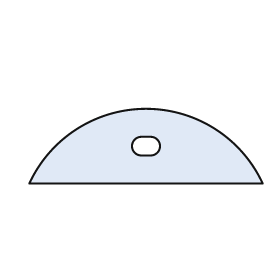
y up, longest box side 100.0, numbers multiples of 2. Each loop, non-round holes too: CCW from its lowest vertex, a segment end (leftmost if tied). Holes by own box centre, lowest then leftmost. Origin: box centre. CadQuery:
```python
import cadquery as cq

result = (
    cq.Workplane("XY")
    .moveTo(-50.0, -16.0)
    .lineTo(50.0, -16.0)
    .threePointArc((0.0, 16.0), (-50.0, -16.0))
    .close()
    .moveTo(-2.0, -4.0)
    .lineTo(2.0, -4.0)
    .threePointArc((6.0, 0.0), (2.0, 4.0))
    .lineTo(-2.0, 4.0)
    .threePointArc((-6.0, 0.0), (-2.0, -4.0))
    .close()
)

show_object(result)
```